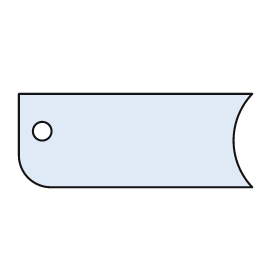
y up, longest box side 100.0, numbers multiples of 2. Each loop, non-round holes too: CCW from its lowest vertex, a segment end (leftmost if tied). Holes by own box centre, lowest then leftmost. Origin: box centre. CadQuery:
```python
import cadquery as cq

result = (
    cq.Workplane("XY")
    .moveTo(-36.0, -20.0)
    .lineTo(50.0, -20.0)
    .threePointArc((42.0, 0.0), (50.0, 20.0))
    .lineTo(-50.0, 20.0)
    .lineTo(-50.0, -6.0)
    .threePointArc((-46.0, -16.0), (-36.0, -20.0))
    .close()
    .moveTo(-40.0, 4.0)
    .circle(4.0)
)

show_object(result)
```